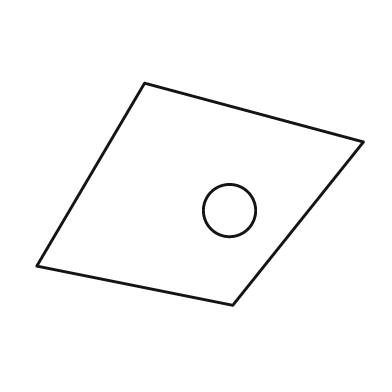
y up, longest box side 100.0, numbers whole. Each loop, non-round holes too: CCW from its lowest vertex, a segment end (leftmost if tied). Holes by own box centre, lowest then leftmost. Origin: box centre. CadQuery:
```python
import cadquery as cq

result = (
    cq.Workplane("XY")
    .moveTo(10.0, -34.0)
    .lineTo(50.0, 16.0)
    .lineTo(-17.0, 34.0)
    .lineTo(-50.0, -22.0)
    .close()
    .moveTo(9.0, -5.0)
    .circle(8.0)
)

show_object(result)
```